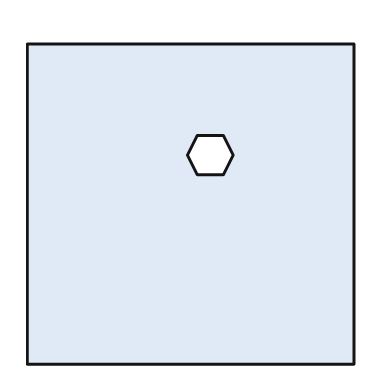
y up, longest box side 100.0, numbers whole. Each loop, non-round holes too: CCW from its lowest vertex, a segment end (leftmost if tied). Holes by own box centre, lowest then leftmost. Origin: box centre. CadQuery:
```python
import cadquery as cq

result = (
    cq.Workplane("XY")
    .moveTo(-50.0, -49.0)
    .lineTo(50.0, -49.0)
    .lineTo(50.0, 49.0)
    .lineTo(-50.0, 49.0)
    .close()
    .moveTo(2.0, 9.0)
    .lineTo(10.0, 9.0)
    .lineTo(13.0, 15.0)
    .lineTo(10.0, 21.0)
    .lineTo(2.0, 21.0)
    .lineTo(-1.0, 15.0)
    .close()
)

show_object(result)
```